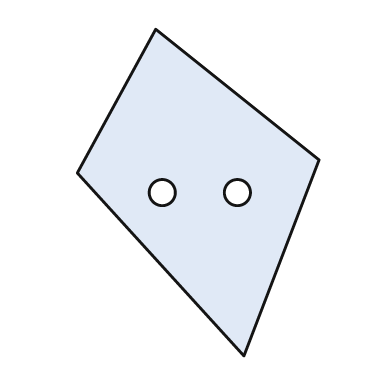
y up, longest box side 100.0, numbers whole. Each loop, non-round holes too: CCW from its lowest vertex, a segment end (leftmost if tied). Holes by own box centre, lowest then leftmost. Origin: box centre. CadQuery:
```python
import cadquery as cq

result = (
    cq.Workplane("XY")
    .moveTo(14.0, -50.0)
    .lineTo(37.0, 10.0)
    .lineTo(-13.0, 50.0)
    .lineTo(-37.0, 6.0)
    .close()
    .moveTo(-11.0, 0.0)
    .circle(4.0)
    .moveTo(12.0, 0.0)
    .circle(4.0)
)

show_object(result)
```